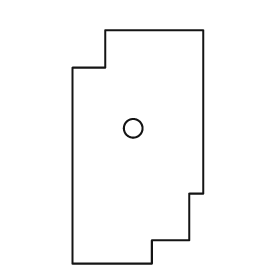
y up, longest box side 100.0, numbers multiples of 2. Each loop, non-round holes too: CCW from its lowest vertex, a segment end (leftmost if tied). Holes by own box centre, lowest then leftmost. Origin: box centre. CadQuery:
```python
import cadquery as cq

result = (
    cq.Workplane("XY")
    .moveTo(-28.0, -50.0)
    .lineTo(6.0, -50.0)
    .lineTo(6.0, -40.0)
    .lineTo(22.0, -40.0)
    .lineTo(22.0, -20.0)
    .lineTo(28.0, -20.0)
    .lineTo(28.0, 50.0)
    .lineTo(-14.0, 50.0)
    .lineTo(-14.0, 34.0)
    .lineTo(-28.0, 34.0)
    .close()
    .moveTo(-2.0, 8.0)
    .circle(4.0)
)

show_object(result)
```